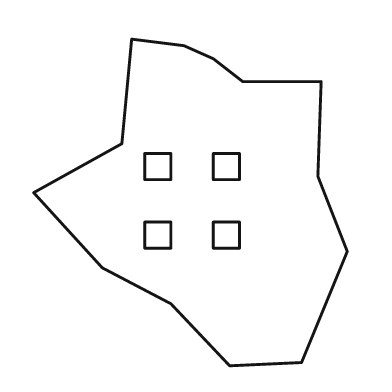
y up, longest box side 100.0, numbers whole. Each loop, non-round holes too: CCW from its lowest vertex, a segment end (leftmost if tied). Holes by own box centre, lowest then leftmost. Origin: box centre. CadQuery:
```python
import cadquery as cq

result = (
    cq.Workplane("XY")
    .moveTo(12.0, -50.0)
    .lineTo(34.0, -49.0)
    .lineTo(48.0, -15.0)
    .lineTo(39.0, 8.0)
    .lineTo(40.0, 37.0)
    .lineTo(16.0, 37.0)
    .lineTo(7.0, 44.0)
    .lineTo(-2.0, 48.0)
    .lineTo(-18.0, 50.0)
    .lineTo(-21.0, 18.0)
    .lineTo(-48.0, 3.0)
    .lineTo(-27.0, -20.0)
    .lineTo(-6.0, -31.0)
    .close()
    .moveTo(-14.0, -14.0)
    .lineTo(-6.0, -14.0)
    .lineTo(-6.0, -6.0)
    .lineTo(-14.0, -6.0)
    .close()
    .moveTo(7.0, -14.0)
    .lineTo(15.0, -14.0)
    .lineTo(15.0, -6.0)
    .lineTo(7.0, -6.0)
    .close()
    .moveTo(-14.0, 7.0)
    .lineTo(-6.0, 7.0)
    .lineTo(-6.0, 15.0)
    .lineTo(-14.0, 15.0)
    .close()
    .moveTo(7.0, 7.0)
    .lineTo(15.0, 7.0)
    .lineTo(15.0, 15.0)
    .lineTo(7.0, 15.0)
    .close()
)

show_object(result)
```